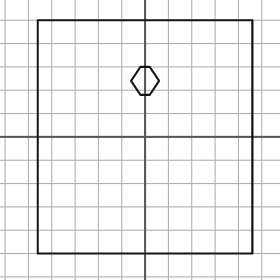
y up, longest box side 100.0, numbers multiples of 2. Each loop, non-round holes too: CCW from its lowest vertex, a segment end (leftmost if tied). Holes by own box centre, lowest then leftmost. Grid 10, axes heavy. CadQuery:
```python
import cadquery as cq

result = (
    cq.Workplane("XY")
    .moveTo(-46.0, -50.0)
    .lineTo(46.0, -50.0)
    .lineTo(46.0, 50.0)
    .lineTo(-46.0, 50.0)
    .close()
    .moveTo(-2.0, 18.0)
    .lineTo(2.0, 18.0)
    .lineTo(6.0, 24.0)
    .lineTo(2.0, 30.0)
    .lineTo(-2.0, 30.0)
    .lineTo(-6.0, 24.0)
    .close()
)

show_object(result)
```